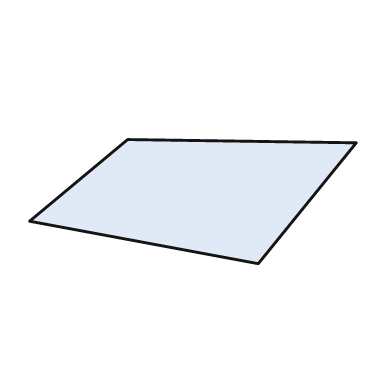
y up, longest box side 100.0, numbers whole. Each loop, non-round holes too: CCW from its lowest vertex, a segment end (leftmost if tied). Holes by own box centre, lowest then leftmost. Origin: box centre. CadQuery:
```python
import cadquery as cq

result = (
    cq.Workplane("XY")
    .moveTo(20.0, -19.0)
    .lineTo(50.0, 18.0)
    .lineTo(-20.0, 19.0)
    .lineTo(-50.0, -6.0)
    .close()
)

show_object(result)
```